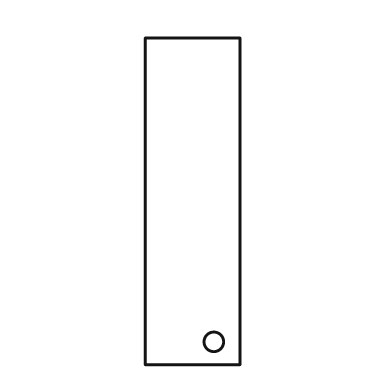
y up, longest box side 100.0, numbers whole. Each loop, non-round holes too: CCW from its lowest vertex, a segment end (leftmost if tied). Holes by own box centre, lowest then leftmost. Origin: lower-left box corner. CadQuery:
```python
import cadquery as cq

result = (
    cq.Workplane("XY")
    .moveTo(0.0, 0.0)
    .lineTo(29.0, 0.0)
    .lineTo(29.0, 100.0)
    .lineTo(0.0, 100.0)
    .close()
    .moveTo(21.0, 7.0)
    .circle(3.0)
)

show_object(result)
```